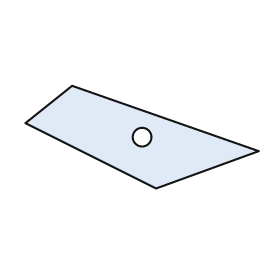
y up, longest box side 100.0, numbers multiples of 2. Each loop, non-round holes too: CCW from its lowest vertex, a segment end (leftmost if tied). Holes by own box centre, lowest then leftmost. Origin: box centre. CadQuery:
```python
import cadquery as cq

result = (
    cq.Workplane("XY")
    .moveTo(6.0, -22.0)
    .lineTo(50.0, -6.0)
    .lineTo(-30.0, 22.0)
    .lineTo(-50.0, 6.0)
    .close()
    .moveTo(0.0, 0.0)
    .circle(4.0)
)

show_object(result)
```